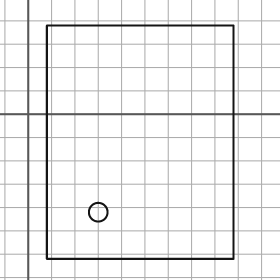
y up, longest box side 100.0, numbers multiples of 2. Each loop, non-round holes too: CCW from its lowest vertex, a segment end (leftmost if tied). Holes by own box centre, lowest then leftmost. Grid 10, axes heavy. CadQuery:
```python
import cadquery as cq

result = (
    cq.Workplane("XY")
    .moveTo(8.0, -62.0)
    .lineTo(88.0, -62.0)
    .lineTo(88.0, 38.0)
    .lineTo(8.0, 38.0)
    .close()
    .moveTo(30.0, -42.0)
    .circle(4.0)
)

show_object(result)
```